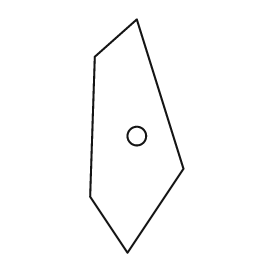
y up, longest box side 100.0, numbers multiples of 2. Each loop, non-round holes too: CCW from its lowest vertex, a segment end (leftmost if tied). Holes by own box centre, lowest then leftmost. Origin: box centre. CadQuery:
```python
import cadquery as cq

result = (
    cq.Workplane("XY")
    .moveTo(-4.0, -50.0)
    .lineTo(20.0, -14.0)
    .lineTo(0.0, 50.0)
    .lineTo(-18.0, 34.0)
    .lineTo(-20.0, -26.0)
    .close()
    .moveTo(0.0, 0.0)
    .circle(4.0)
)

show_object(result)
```